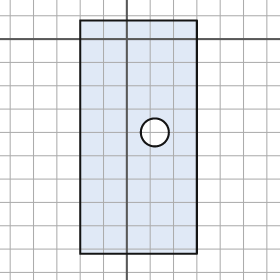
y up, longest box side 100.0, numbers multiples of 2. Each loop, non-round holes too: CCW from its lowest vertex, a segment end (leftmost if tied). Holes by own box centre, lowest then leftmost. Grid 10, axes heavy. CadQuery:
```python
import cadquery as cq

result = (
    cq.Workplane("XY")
    .moveTo(-20.0, -92.0)
    .lineTo(30.0, -92.0)
    .lineTo(30.0, 8.0)
    .lineTo(-20.0, 8.0)
    .close()
    .moveTo(12.0, -40.0)
    .circle(6.0)
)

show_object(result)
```